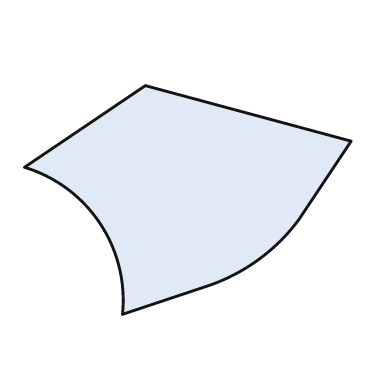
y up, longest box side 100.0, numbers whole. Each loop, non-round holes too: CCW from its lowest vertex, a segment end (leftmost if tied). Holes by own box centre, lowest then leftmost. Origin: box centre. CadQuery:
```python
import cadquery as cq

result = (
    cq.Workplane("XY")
    .moveTo(-20.0, -35.0)
    .lineTo(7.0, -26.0)
    .threePointArc((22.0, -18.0), (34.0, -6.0))
    .lineTo(50.0, 18.0)
    .lineTo(-13.0, 35.0)
    .lineTo(-50.0, 10.0)
    .threePointArc((-27.0, -7.0), (-20.0, -35.0))
    .close()
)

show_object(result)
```